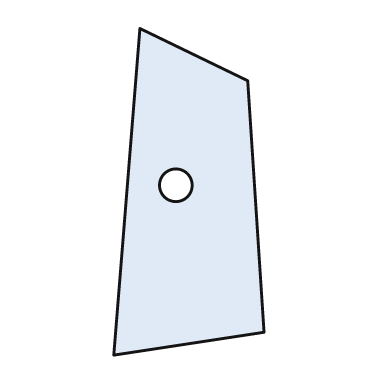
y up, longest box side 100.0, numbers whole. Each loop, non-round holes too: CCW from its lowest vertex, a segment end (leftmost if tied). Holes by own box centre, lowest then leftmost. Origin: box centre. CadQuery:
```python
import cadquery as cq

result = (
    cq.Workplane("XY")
    .moveTo(-23.0, -50.0)
    .lineTo(23.0, -43.0)
    .lineTo(18.0, 34.0)
    .lineTo(-15.0, 50.0)
    .close()
    .moveTo(-4.0, 2.0)
    .circle(5.0)
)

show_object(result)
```